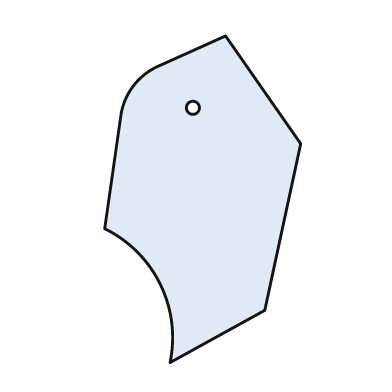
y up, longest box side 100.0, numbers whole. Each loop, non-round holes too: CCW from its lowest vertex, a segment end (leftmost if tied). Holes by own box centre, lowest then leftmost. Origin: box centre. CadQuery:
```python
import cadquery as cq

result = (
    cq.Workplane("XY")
    .moveTo(-10.0, -50.0)
    .lineTo(19.0, -34.0)
    .lineTo(30.0, 17.0)
    .lineTo(7.0, 50.0)
    .lineTo(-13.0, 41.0)
    .threePointArc((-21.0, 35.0), (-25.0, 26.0))
    .lineTo(-30.0, -9.0)
    .threePointArc((-13.0, -26.0), (-10.0, -50.0))
    .close()
    .moveTo(-3.0, 28.0)
    .circle(2.0)
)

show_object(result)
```